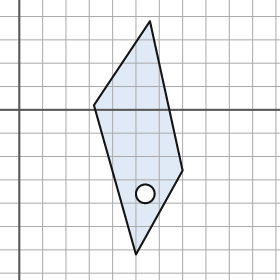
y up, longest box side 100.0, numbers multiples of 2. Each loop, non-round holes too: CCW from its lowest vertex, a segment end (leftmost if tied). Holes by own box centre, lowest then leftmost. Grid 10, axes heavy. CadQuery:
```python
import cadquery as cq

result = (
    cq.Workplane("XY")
    .moveTo(50.0, -62.0)
    .lineTo(70.0, -26.0)
    .lineTo(56.0, 38.0)
    .lineTo(32.0, 2.0)
    .close()
    .moveTo(54.0, -36.0)
    .circle(4.0)
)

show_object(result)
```